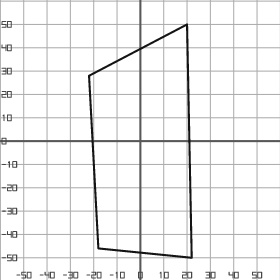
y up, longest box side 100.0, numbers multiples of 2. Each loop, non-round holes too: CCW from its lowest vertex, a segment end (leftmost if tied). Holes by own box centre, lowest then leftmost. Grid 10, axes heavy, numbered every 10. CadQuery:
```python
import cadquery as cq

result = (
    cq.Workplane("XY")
    .moveTo(22.0, -50.0)
    .lineTo(20.0, 50.0)
    .lineTo(-22.0, 28.0)
    .lineTo(-18.0, -46.0)
    .close()
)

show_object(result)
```